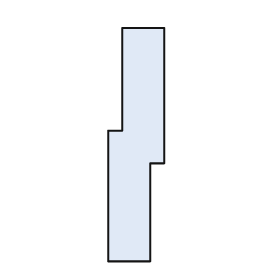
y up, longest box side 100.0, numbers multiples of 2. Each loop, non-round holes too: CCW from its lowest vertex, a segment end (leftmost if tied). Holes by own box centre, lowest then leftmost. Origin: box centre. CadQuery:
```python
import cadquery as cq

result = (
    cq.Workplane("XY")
    .moveTo(-12.0, -50.0)
    .lineTo(6.0, -50.0)
    .lineTo(6.0, -8.0)
    .lineTo(12.0, -8.0)
    .lineTo(12.0, 50.0)
    .lineTo(-6.0, 50.0)
    .lineTo(-6.0, 6.0)
    .lineTo(-12.0, 6.0)
    .close()
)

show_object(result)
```